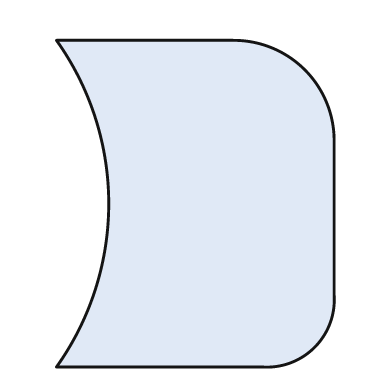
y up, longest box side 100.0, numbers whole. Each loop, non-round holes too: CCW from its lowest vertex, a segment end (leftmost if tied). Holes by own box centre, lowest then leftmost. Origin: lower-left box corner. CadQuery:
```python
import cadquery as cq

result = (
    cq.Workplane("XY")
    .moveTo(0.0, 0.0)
    .lineTo(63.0, 0.0)
    .threePointArc((79.0, 6.0), (85.0, 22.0))
    .lineTo(85.0, 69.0)
    .threePointArc((76.0, 91.0), (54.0, 100.0))
    .lineTo(0.0, 100.0)
    .threePointArc((16.0, 50.0), (0.0, 0.0))
    .close()
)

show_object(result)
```